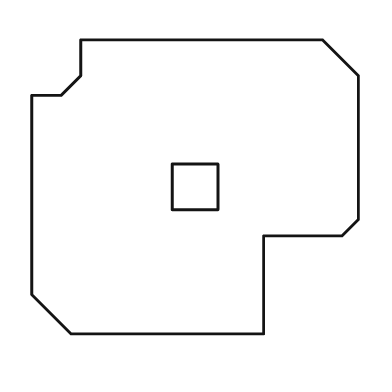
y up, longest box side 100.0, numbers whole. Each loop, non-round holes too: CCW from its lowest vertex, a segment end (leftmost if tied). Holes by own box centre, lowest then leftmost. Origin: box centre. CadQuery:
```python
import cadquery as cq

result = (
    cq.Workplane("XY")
    .moveTo(-38.0, -45.0)
    .lineTo(21.0, -45.0)
    .lineTo(21.0, -15.0)
    .lineTo(45.0, -15.0)
    .lineTo(50.0, -10.0)
    .lineTo(50.0, 34.0)
    .lineTo(39.0, 45.0)
    .lineTo(-35.0, 45.0)
    .lineTo(-35.0, 34.0)
    .lineTo(-41.0, 28.0)
    .lineTo(-50.0, 28.0)
    .lineTo(-50.0, -33.0)
    .close()
    .moveTo(-7.0, -7.0)
    .lineTo(7.0, -7.0)
    .lineTo(7.0, 7.0)
    .lineTo(-7.0, 7.0)
    .close()
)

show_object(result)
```